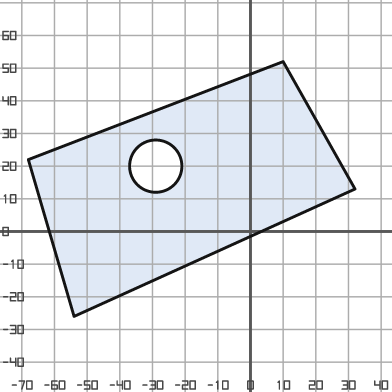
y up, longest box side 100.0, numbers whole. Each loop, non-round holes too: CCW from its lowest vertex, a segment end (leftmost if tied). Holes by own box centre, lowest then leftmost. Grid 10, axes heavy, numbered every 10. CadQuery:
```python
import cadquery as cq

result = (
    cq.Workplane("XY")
    .moveTo(-54.0, -26.0)
    .lineTo(32.0, 13.0)
    .lineTo(10.0, 52.0)
    .lineTo(-68.0, 22.0)
    .close()
    .moveTo(-29.0, 20.0)
    .circle(8.0)
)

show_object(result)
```